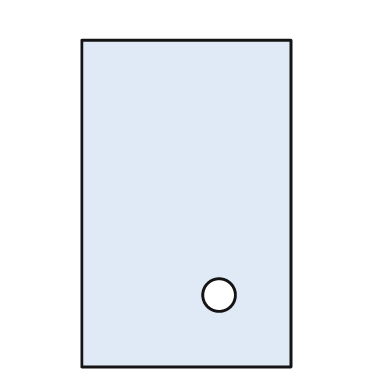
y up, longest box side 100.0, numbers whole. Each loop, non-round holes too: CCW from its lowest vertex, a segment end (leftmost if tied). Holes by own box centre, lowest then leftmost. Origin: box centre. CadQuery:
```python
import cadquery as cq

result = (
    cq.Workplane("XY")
    .moveTo(-32.0, -50.0)
    .lineTo(32.0, -50.0)
    .lineTo(32.0, 50.0)
    .lineTo(-32.0, 50.0)
    .close()
    .moveTo(10.0, -28.0)
    .circle(5.0)
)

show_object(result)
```